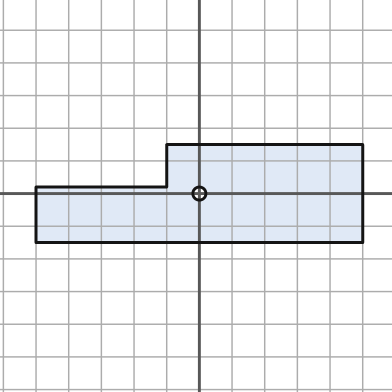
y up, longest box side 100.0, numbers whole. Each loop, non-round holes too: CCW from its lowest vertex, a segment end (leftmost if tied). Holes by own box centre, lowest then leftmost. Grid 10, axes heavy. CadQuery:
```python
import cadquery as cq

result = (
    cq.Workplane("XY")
    .moveTo(-50.0, -15.0)
    .lineTo(50.0, -15.0)
    .lineTo(50.0, 15.0)
    .lineTo(-10.0, 15.0)
    .lineTo(-10.0, 2.0)
    .lineTo(-50.0, 2.0)
    .close()
    .moveTo(0.0, 0.0)
    .circle(2.0)
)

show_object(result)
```